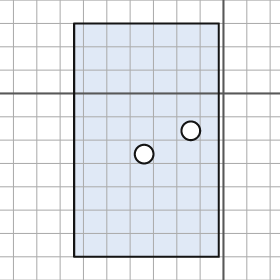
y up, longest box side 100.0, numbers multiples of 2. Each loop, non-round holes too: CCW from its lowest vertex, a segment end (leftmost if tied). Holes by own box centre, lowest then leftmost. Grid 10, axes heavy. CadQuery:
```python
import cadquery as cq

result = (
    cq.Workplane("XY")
    .moveTo(-64.0, -70.0)
    .lineTo(-2.0, -70.0)
    .lineTo(-2.0, 30.0)
    .lineTo(-64.0, 30.0)
    .close()
    .moveTo(-34.0, -26.0)
    .circle(4.0)
    .moveTo(-14.0, -16.0)
    .circle(4.0)
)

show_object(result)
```